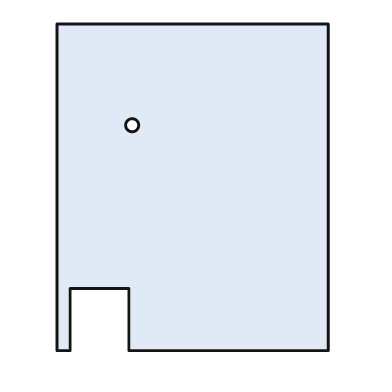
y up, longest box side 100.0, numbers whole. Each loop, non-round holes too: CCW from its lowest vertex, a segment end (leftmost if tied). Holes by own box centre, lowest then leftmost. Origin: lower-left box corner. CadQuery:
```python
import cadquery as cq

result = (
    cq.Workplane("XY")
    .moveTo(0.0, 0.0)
    .lineTo(4.0, 0.0)
    .lineTo(4.0, 19.0)
    .lineTo(22.0, 19.0)
    .lineTo(22.0, 0.0)
    .lineTo(83.0, 0.0)
    .lineTo(83.0, 100.0)
    .lineTo(0.0, 100.0)
    .close()
    .moveTo(23.0, 69.0)
    .circle(2.0)
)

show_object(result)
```